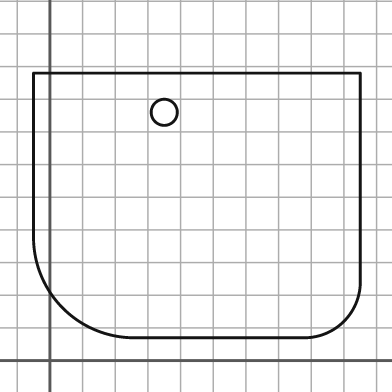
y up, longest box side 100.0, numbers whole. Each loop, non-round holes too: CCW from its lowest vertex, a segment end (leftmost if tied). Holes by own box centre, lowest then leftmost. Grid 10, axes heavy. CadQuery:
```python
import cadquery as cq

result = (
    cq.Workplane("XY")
    .moveTo(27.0, 7.0)
    .lineTo(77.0, 7.0)
    .threePointArc((90.0, 12.0), (95.0, 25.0))
    .lineTo(95.0, 88.0)
    .lineTo(-5.0, 88.0)
    .lineTo(-5.0, 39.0)
    .threePointArc((4.0, 16.0), (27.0, 7.0))
    .close()
    .moveTo(35.0, 76.0)
    .circle(4.0)
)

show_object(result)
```